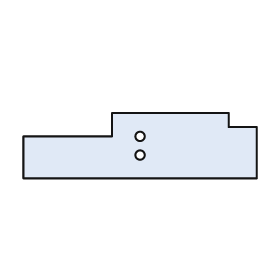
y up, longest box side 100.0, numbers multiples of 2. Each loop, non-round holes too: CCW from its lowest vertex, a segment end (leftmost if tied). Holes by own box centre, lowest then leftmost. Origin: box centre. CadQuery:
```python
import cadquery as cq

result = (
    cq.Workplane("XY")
    .moveTo(-50.0, -14.0)
    .lineTo(50.0, -14.0)
    .lineTo(50.0, 8.0)
    .lineTo(38.0, 8.0)
    .lineTo(38.0, 14.0)
    .lineTo(-12.0, 14.0)
    .lineTo(-12.0, 4.0)
    .lineTo(-50.0, 4.0)
    .close()
    .moveTo(0.0, -4.0)
    .circle(2.0)
    .moveTo(0.0, 4.0)
    .circle(2.0)
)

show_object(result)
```